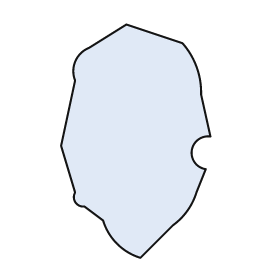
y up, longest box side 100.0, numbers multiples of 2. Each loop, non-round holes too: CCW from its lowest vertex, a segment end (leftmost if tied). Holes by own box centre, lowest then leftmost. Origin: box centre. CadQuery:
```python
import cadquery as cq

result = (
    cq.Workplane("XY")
    .moveTo(2.0, -50.0)
    .lineTo(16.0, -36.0)
    .threePointArc((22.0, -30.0), (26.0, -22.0))
    .lineTo(30.0, -12.0)
    .threePointArc((24.0, -4.0), (32.0, 2.0))
    .lineTo(28.0, 20.0)
    .threePointArc((26.0, 32.0), (20.0, 42.0))
    .lineTo(-4.0, 50.0)
    .lineTo(-20.0, 40.0)
    .threePointArc((-26.0, 34.0), (-26.0, 26.0))
    .lineTo(-32.0, -2.0)
    .lineTo(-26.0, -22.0)
    .threePointArc((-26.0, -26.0), (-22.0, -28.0))
    .lineTo(-14.0, -34.0)
    .threePointArc((-8.0, -44.0), (2.0, -50.0))
    .close()
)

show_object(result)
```